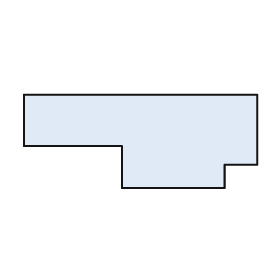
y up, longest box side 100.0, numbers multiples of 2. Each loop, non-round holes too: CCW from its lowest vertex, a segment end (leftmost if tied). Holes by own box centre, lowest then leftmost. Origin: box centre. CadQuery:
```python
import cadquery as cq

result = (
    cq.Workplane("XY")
    .moveTo(-8.0, -20.0)
    .lineTo(36.0, -20.0)
    .lineTo(36.0, -10.0)
    .lineTo(50.0, -10.0)
    .lineTo(50.0, 20.0)
    .lineTo(-50.0, 20.0)
    .lineTo(-50.0, -2.0)
    .lineTo(-8.0, -2.0)
    .close()
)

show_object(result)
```